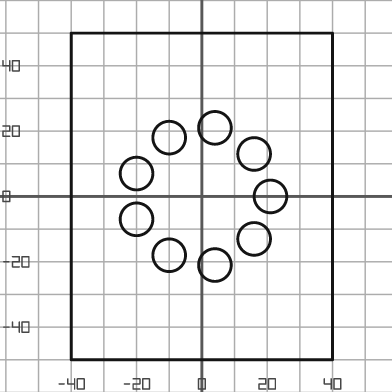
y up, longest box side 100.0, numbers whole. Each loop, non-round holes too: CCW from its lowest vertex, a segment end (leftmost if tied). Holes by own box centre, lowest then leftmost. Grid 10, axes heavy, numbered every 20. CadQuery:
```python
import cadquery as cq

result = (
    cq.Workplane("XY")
    .moveTo(-40.0, -50.0)
    .lineTo(40.0, -50.0)
    .lineTo(40.0, 50.0)
    .lineTo(-40.0, 50.0)
    .close()
    .moveTo(4.0, -21.0)
    .circle(5.0)
    .moveTo(-10.0, -18.0)
    .circle(5.0)
    .moveTo(16.0, -13.0)
    .circle(5.0)
    .moveTo(-20.0, -7.0)
    .circle(5.0)
    .moveTo(21.0, 0.0)
    .circle(5.0)
    .moveTo(-20.0, 7.0)
    .circle(5.0)
    .moveTo(16.0, 13.0)
    .circle(5.0)
    .moveTo(-10.0, 18.0)
    .circle(5.0)
    .moveTo(4.0, 21.0)
    .circle(5.0)
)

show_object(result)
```